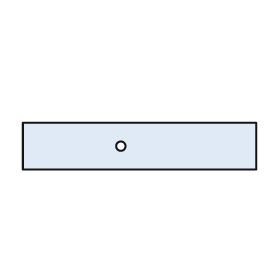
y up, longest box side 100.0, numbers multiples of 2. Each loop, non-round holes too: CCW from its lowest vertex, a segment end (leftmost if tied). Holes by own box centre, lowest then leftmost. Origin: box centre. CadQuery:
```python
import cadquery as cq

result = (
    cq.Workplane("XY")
    .moveTo(-50.0, -10.0)
    .lineTo(50.0, -10.0)
    .lineTo(50.0, 10.0)
    .lineTo(-50.0, 10.0)
    .close()
    .moveTo(-8.0, 0.0)
    .circle(2.0)
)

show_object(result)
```